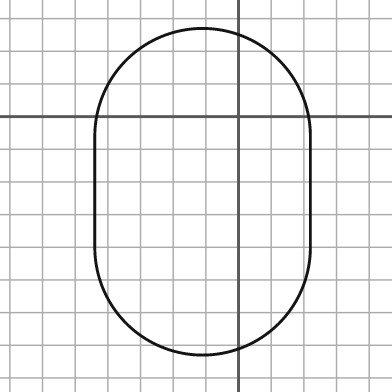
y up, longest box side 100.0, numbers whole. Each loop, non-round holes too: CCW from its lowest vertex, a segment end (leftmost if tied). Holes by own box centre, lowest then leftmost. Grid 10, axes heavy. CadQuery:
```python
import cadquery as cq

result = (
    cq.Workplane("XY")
    .moveTo(-44.0, -40.0)
    .threePointArc((-11.0, -73.0), (22.0, -40.0))
    .lineTo(22.0, -6.0)
    .threePointArc((-11.0, 27.0), (-44.0, -6.0))
    .close()
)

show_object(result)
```